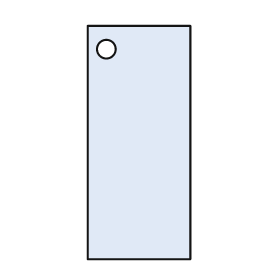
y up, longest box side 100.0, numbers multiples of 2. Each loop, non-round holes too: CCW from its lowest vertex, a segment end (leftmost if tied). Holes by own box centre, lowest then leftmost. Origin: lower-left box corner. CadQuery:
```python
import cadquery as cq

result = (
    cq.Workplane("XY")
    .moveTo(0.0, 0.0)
    .lineTo(44.0, 0.0)
    .lineTo(44.0, 100.0)
    .lineTo(0.0, 100.0)
    .close()
    .moveTo(8.0, 90.0)
    .circle(4.0)
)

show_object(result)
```